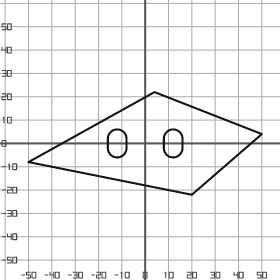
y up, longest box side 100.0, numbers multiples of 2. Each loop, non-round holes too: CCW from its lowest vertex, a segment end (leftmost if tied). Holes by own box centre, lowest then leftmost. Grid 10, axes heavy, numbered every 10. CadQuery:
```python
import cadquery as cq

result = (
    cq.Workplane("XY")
    .moveTo(20.0, -22.0)
    .lineTo(50.0, 4.0)
    .lineTo(4.0, 22.0)
    .lineTo(-50.0, -8.0)
    .close()
    .moveTo(-16.0, -2.0)
    .threePointArc((-12.0, -6.0), (-8.0, -2.0))
    .lineTo(-8.0, 2.0)
    .threePointArc((-12.0, 6.0), (-16.0, 2.0))
    .close()
    .moveTo(8.0, -2.0)
    .threePointArc((12.0, -6.0), (16.0, -2.0))
    .lineTo(16.0, 2.0)
    .threePointArc((12.0, 6.0), (8.0, 2.0))
    .close()
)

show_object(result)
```